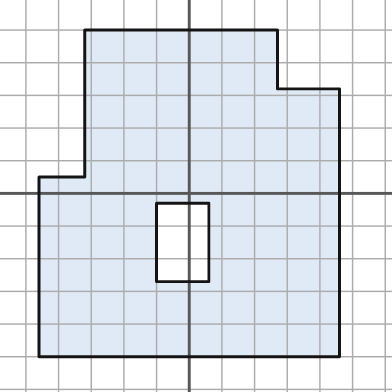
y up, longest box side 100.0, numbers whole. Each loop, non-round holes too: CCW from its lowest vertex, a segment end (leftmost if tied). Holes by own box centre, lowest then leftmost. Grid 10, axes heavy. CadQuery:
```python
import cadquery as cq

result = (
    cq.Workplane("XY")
    .moveTo(-46.0, -50.0)
    .lineTo(46.0, -50.0)
    .lineTo(46.0, 32.0)
    .lineTo(27.0, 32.0)
    .lineTo(27.0, 50.0)
    .lineTo(-32.0, 50.0)
    .lineTo(-32.0, 5.0)
    .lineTo(-46.0, 5.0)
    .close()
    .moveTo(-10.0, -27.0)
    .lineTo(6.0, -27.0)
    .lineTo(6.0, -3.0)
    .lineTo(-10.0, -3.0)
    .close()
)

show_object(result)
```